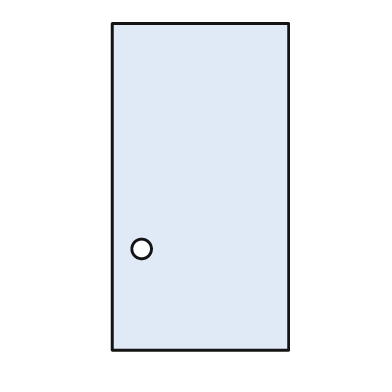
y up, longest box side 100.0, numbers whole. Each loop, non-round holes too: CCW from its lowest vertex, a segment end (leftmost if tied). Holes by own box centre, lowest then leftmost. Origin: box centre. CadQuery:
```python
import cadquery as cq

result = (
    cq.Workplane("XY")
    .moveTo(-27.0, -50.0)
    .lineTo(27.0, -50.0)
    .lineTo(27.0, 50.0)
    .lineTo(-27.0, 50.0)
    .close()
    .moveTo(-18.0, -19.0)
    .circle(3.0)
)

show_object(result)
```